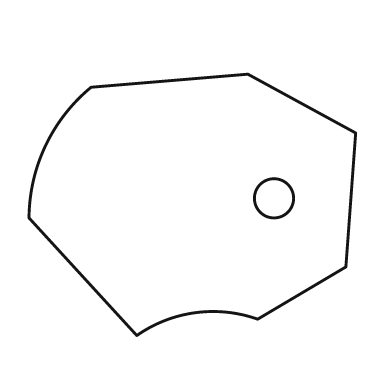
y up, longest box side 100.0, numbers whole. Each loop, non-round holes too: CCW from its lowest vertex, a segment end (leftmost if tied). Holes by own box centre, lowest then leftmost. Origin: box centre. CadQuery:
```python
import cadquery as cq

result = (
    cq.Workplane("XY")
    .moveTo(-17.0, -40.0)
    .threePointArc((1.0, -33.0), (20.0, -35.0))
    .lineTo(47.0, -19.0)
    .lineTo(50.0, 22.0)
    .lineTo(17.0, 40.0)
    .lineTo(-31.0, 36.0)
    .threePointArc((-45.0, 18.0), (-50.0, -4.0))
    .close()
    .moveTo(25.0, 2.0)
    .circle(6.0)
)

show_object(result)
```